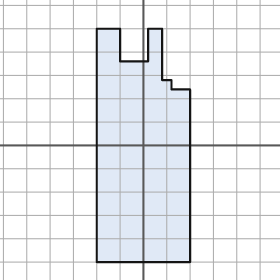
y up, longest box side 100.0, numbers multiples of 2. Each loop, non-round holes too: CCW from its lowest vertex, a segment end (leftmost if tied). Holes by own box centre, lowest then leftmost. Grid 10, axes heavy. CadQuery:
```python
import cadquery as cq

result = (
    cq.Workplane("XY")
    .moveTo(-20.0, -50.0)
    .lineTo(20.0, -50.0)
    .lineTo(20.0, 24.0)
    .lineTo(12.0, 24.0)
    .lineTo(12.0, 28.0)
    .lineTo(8.0, 28.0)
    .lineTo(8.0, 50.0)
    .lineTo(2.0, 50.0)
    .lineTo(2.0, 36.0)
    .lineTo(-10.0, 36.0)
    .lineTo(-10.0, 50.0)
    .lineTo(-20.0, 50.0)
    .close()
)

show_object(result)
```